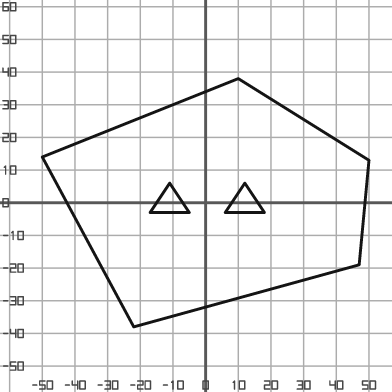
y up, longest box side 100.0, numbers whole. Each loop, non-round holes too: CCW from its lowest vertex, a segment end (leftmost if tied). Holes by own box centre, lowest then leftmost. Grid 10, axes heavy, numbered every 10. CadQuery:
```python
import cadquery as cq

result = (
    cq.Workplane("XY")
    .moveTo(-22.0, -38.0)
    .lineTo(47.0, -19.0)
    .lineTo(50.0, 13.0)
    .lineTo(10.0, 38.0)
    .lineTo(-50.0, 14.0)
    .close()
    .moveTo(-17.0, -3.0)
    .lineTo(-5.0, -3.0)
    .lineTo(-11.0, 6.0)
    .close()
    .moveTo(6.0, -3.0)
    .lineTo(18.0, -3.0)
    .lineTo(12.0, 6.0)
    .close()
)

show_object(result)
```